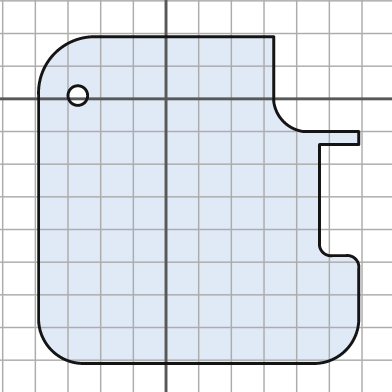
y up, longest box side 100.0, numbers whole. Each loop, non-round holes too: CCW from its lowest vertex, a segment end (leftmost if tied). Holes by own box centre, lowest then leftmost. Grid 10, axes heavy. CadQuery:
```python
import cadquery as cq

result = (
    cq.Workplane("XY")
    .moveTo(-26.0, -81.0)
    .lineTo(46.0, -81.0)
    .threePointArc((55.0, -77.0), (59.0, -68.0))
    .lineTo(59.0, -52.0)
    .threePointArc((58.0, -49.0), (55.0, -48.0))
    .lineTo(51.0, -48.0)
    .threePointArc((48.0, -47.0), (47.0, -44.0))
    .lineTo(47.0, -14.0)
    .lineTo(59.0, -14.0)
    .lineTo(59.0, -10.0)
    .lineTo(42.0, -10.0)
    .threePointArc((36.0, -7.0), (33.0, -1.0))
    .lineTo(33.0, 19.0)
    .lineTo(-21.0, 19.0)
    .threePointArc((-34.0, 14.0), (-39.0, 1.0))
    .lineTo(-39.0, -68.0)
    .threePointArc((-35.0, -77.0), (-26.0, -81.0))
    .close()
    .moveTo(-27.0, 1.0)
    .circle(3.0)
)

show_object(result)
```